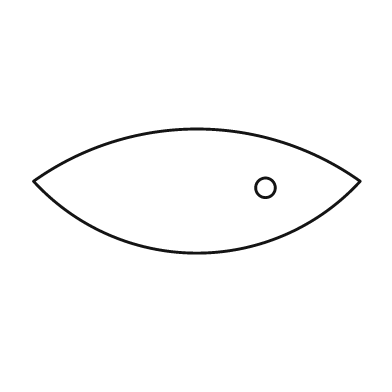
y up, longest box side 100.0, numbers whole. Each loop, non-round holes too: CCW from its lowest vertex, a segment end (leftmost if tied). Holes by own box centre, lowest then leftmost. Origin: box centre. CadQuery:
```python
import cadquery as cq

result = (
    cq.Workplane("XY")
    .moveTo(-50.0, 3.0)
    .threePointArc((0.0, -19.0), (50.0, 3.0))
    .threePointArc((0.0, 19.0), (-50.0, 3.0))
    .close()
    .moveTo(21.0, 1.0)
    .circle(3.0)
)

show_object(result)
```